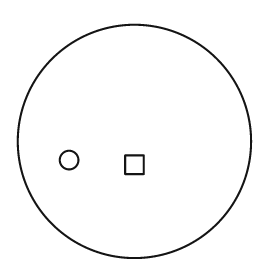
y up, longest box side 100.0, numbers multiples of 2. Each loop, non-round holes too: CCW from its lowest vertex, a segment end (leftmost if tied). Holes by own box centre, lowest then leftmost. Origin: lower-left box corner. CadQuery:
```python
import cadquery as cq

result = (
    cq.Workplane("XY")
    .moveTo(50.0, 50.0)
    .circle(50.0)
    .moveTo(46.0, 36.0)
    .lineTo(54.0, 36.0)
    .lineTo(54.0, 44.0)
    .lineTo(46.0, 44.0)
    .close()
    .moveTo(22.0, 42.0)
    .circle(4.0)
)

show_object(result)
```